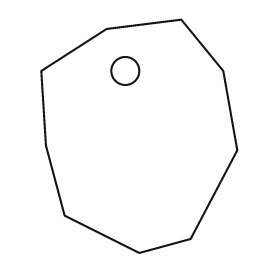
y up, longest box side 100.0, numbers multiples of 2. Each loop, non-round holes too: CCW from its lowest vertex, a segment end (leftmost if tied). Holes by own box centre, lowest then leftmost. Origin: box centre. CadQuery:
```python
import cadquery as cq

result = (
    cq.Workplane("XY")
    .moveTo(0.0, -50.0)
    .lineTo(22.0, -44.0)
    .lineTo(42.0, -6.0)
    .lineTo(36.0, 28.0)
    .lineTo(18.0, 50.0)
    .lineTo(-14.0, 46.0)
    .lineTo(-42.0, 28.0)
    .lineTo(-40.0, -4.0)
    .lineTo(-32.0, -34.0)
    .close()
    .moveTo(-6.0, 28.0)
    .circle(6.0)
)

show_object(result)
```